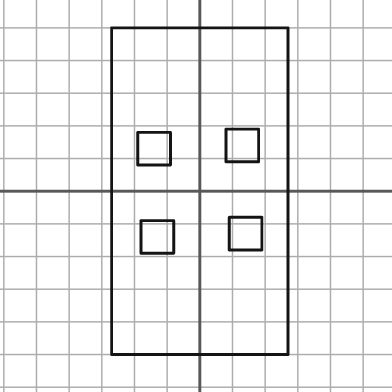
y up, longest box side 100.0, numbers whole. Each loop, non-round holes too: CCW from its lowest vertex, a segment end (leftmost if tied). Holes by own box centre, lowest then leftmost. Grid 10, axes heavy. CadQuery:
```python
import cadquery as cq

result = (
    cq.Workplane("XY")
    .moveTo(-27.0, -50.0)
    .lineTo(27.0, -50.0)
    .lineTo(27.0, 50.0)
    .lineTo(-27.0, 50.0)
    .close()
    .moveTo(-18.0, -19.0)
    .lineTo(-8.0, -19.0)
    .lineTo(-8.0, -9.0)
    .lineTo(-18.0, -9.0)
    .close()
    .moveTo(9.0, -18.0)
    .lineTo(19.0, -18.0)
    .lineTo(19.0, -8.0)
    .lineTo(9.0, -8.0)
    .close()
    .moveTo(-19.0, 8.0)
    .lineTo(-9.0, 8.0)
    .lineTo(-9.0, 18.0)
    .lineTo(-19.0, 18.0)
    .close()
    .moveTo(8.0, 9.0)
    .lineTo(18.0, 9.0)
    .lineTo(18.0, 19.0)
    .lineTo(8.0, 19.0)
    .close()
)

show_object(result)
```